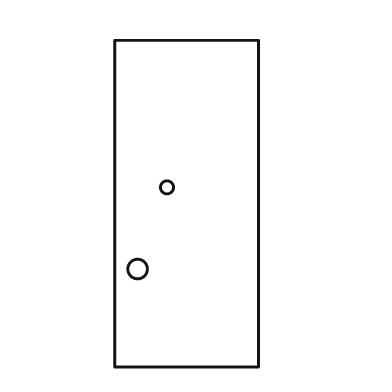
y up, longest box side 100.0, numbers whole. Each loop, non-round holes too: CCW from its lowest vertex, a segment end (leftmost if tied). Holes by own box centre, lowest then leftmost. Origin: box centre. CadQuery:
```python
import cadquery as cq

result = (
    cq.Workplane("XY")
    .moveTo(-22.0, -50.0)
    .lineTo(22.0, -50.0)
    .lineTo(22.0, 50.0)
    .lineTo(-22.0, 50.0)
    .close()
    .moveTo(-15.0, -20.0)
    .circle(3.0)
    .moveTo(-6.0, 5.0)
    .circle(2.0)
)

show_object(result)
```